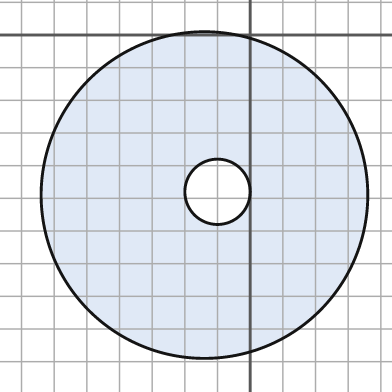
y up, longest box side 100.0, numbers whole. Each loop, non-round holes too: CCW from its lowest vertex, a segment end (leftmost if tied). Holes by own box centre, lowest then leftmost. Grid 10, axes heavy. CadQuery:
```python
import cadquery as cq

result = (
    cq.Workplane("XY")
    .moveTo(-14.0, -49.0)
    .circle(50.0)
    .moveTo(-10.0, -48.0)
    .circle(10.0)
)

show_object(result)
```